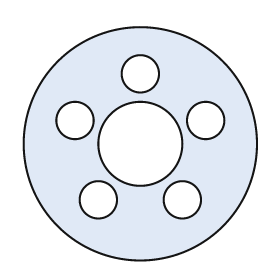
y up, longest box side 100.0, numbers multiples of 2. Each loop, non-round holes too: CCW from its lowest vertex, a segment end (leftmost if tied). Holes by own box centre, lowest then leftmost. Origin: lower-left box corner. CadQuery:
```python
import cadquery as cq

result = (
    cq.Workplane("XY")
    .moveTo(50.0, 50.0)
    .circle(50.0)
    .moveTo(32.0, 26.0)
    .circle(8.0)
    .moveTo(68.0, 26.0)
    .circle(8.0)
    .moveTo(50.0, 50.0)
    .circle(18.0)
    .moveTo(22.0, 60.0)
    .circle(8.0)
    .moveTo(78.0, 60.0)
    .circle(8.0)
    .moveTo(50.0, 80.0)
    .circle(8.0)
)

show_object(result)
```